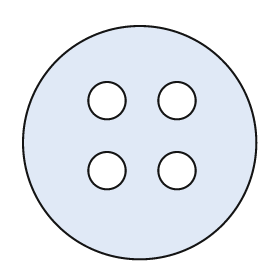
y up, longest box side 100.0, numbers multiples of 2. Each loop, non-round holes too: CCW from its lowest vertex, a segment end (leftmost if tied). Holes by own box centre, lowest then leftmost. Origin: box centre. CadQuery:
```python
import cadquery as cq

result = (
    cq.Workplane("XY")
    .moveTo(0.0, 0.0)
    .circle(50.0)
    .moveTo(-14.0, -12.0)
    .circle(8.0)
    .moveTo(16.0, -12.0)
    .circle(8.0)
    .moveTo(-14.0, 18.0)
    .circle(8.0)
    .moveTo(16.0, 18.0)
    .circle(8.0)
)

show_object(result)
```